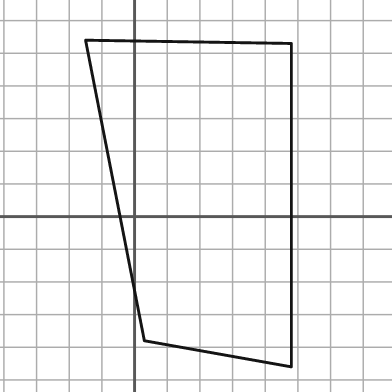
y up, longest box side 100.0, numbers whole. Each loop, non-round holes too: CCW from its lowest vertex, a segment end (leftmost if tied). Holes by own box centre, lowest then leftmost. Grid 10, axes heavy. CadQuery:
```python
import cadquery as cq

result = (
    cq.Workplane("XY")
    .moveTo(48.0, -46.0)
    .lineTo(48.0, 53.0)
    .lineTo(-15.0, 54.0)
    .lineTo(3.0, -38.0)
    .close()
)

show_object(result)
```